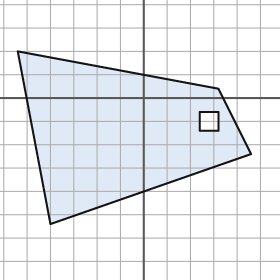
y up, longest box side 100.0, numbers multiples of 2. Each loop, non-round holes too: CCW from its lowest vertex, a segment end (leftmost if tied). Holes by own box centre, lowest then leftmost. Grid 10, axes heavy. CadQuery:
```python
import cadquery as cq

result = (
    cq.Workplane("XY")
    .moveTo(-40.0, -54.0)
    .lineTo(46.0, -24.0)
    .lineTo(32.0, 4.0)
    .lineTo(-54.0, 20.0)
    .close()
    .moveTo(24.0, -14.0)
    .lineTo(32.0, -14.0)
    .lineTo(32.0, -6.0)
    .lineTo(24.0, -6.0)
    .close()
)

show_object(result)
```